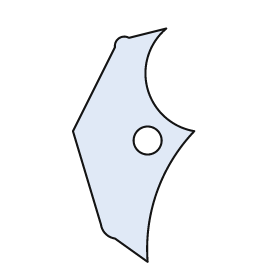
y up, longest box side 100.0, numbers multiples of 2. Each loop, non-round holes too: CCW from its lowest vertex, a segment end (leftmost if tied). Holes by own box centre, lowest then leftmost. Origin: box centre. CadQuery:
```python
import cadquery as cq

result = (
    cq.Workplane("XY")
    .moveTo(6.0, -50.0)
    .threePointArc((10.0, -20.0), (26.0, 6.0))
    .threePointArc((6.0, 24.0), (14.0, 50.0))
    .lineTo(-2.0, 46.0)
    .threePointArc((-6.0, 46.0), (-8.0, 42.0))
    .lineTo(-26.0, 6.0)
    .lineTo(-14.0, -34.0)
    .threePointArc((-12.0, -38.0), (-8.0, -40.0))
    .close()
    .moveTo(6.0, 2.0)
    .circle(6.0)
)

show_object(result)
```